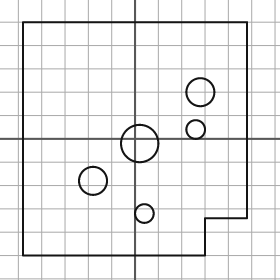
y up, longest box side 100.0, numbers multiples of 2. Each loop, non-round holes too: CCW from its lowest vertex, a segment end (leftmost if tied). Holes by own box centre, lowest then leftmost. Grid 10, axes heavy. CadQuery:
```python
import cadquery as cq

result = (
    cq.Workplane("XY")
    .moveTo(-48.0, -50.0)
    .lineTo(30.0, -50.0)
    .lineTo(30.0, -34.0)
    .lineTo(48.0, -34.0)
    .lineTo(48.0, 50.0)
    .lineTo(-48.0, 50.0)
    .close()
    .moveTo(4.0, -32.0)
    .circle(4.0)
    .moveTo(-18.0, -18.0)
    .circle(6.0)
    .moveTo(2.0, -2.0)
    .circle(8.0)
    .moveTo(26.0, 4.0)
    .circle(4.0)
    .moveTo(28.0, 20.0)
    .circle(6.0)
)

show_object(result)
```